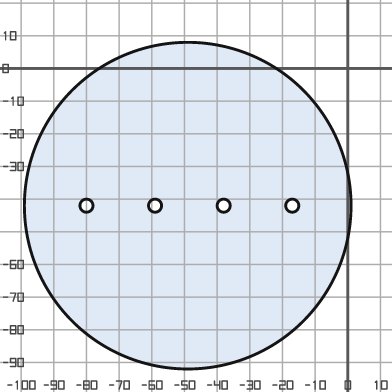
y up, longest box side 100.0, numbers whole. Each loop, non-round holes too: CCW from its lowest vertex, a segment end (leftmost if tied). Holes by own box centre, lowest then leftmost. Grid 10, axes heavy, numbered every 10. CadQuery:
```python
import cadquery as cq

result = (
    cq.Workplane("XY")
    .moveTo(-49.0, -42.0)
    .circle(50.0)
    .moveTo(-80.0, -42.0)
    .circle(2.0)
    .moveTo(-59.0, -42.0)
    .circle(2.0)
    .moveTo(-38.0, -42.0)
    .circle(2.0)
    .moveTo(-17.0, -42.0)
    .circle(2.0)
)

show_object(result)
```